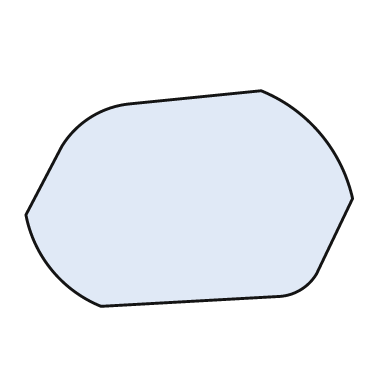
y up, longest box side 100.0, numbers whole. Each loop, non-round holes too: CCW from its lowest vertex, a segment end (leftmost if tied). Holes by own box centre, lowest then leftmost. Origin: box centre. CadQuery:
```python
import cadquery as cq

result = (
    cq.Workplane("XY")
    .moveTo(-27.0, -33.0)
    .lineTo(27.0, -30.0)
    .threePointArc((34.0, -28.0), (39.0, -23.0))
    .lineTo(50.0, 0.0)
    .threePointArc((40.0, 20.0), (22.0, 33.0))
    .lineTo(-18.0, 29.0)
    .threePointArc((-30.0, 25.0), (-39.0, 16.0))
    .lineTo(-50.0, -5.0)
    .threePointArc((-42.0, -22.0), (-27.0, -33.0))
    .close()
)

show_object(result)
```